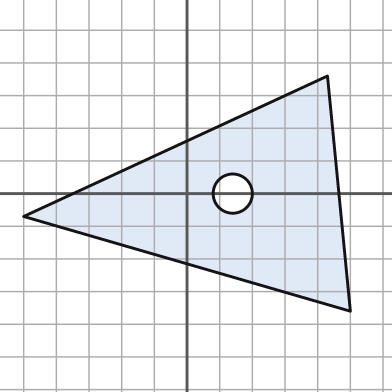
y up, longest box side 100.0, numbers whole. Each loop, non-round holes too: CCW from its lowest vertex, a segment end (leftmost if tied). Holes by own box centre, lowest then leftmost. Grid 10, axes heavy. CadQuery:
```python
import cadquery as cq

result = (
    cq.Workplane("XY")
    .moveTo(50.0, -36.0)
    .lineTo(43.0, 36.0)
    .lineTo(-50.0, -7.0)
    .close()
    .moveTo(14.0, 0.0)
    .circle(6.0)
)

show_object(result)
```